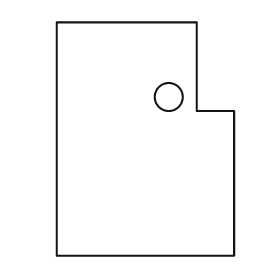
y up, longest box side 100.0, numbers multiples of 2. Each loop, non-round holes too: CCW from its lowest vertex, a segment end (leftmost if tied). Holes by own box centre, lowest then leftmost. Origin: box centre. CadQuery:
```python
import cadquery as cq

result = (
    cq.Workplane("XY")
    .moveTo(-38.0, -50.0)
    .lineTo(38.0, -50.0)
    .lineTo(38.0, 12.0)
    .lineTo(22.0, 12.0)
    .lineTo(22.0, 50.0)
    .lineTo(-38.0, 50.0)
    .close()
    .moveTo(10.0, 18.0)
    .circle(6.0)
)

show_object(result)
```